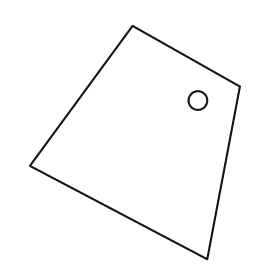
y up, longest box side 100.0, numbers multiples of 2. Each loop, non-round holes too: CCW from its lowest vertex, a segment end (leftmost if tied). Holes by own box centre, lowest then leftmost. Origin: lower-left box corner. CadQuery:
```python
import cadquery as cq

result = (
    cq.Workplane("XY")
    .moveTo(76.0, 0.0)
    .lineTo(90.0, 74.0)
    .lineTo(44.0, 100.0)
    .lineTo(0.0, 40.0)
    .close()
    .moveTo(72.0, 68.0)
    .circle(4.0)
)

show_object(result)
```